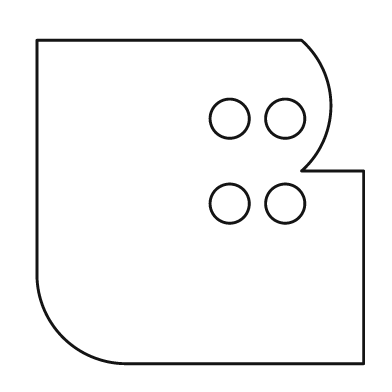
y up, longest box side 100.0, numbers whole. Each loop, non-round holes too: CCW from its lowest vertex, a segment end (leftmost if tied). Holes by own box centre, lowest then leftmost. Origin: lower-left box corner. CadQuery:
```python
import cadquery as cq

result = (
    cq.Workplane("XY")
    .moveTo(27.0, 0.0)
    .lineTo(100.0, 0.0)
    .lineTo(100.0, 59.0)
    .lineTo(81.0, 59.0)
    .threePointArc((90.0, 79.0), (81.0, 99.0))
    .lineTo(0.0, 99.0)
    .lineTo(0.0, 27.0)
    .threePointArc((8.0, 8.0), (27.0, 0.0))
    .close()
    .moveTo(59.0, 49.0)
    .circle(6.0)
    .moveTo(76.0, 49.0)
    .circle(6.0)
    .moveTo(59.0, 75.0)
    .circle(6.0)
    .moveTo(76.0, 75.0)
    .circle(6.0)
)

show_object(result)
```